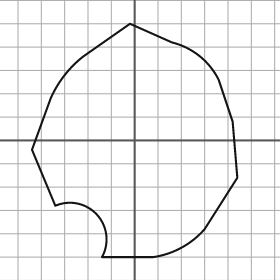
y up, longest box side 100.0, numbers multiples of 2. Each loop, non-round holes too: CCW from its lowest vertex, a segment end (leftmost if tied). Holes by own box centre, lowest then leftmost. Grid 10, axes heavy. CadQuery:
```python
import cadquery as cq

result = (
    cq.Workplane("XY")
    .moveTo(-14.0, -50.0)
    .lineTo(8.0, -50.0)
    .threePointArc((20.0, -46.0), (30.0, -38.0))
    .lineTo(44.0, -16.0)
    .lineTo(42.0, 8.0)
    .lineTo(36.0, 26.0)
    .threePointArc((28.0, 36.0), (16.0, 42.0))
    .lineTo(-2.0, 50.0)
    .lineTo(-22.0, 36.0)
    .threePointArc((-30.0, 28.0), (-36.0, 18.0))
    .lineTo(-44.0, -4.0)
    .lineTo(-34.0, -28.0)
    .threePointArc((-16.0, -32.0), (-14.0, -50.0))
    .close()
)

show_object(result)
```